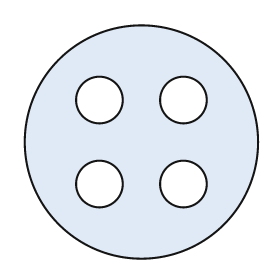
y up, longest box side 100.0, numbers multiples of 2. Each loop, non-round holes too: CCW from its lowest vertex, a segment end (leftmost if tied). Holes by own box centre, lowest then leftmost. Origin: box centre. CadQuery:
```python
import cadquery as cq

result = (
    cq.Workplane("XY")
    .moveTo(0.0, 0.0)
    .circle(50.0)
    .moveTo(-18.0, -18.0)
    .circle(10.0)
    .moveTo(18.0, -18.0)
    .circle(10.0)
    .moveTo(-18.0, 18.0)
    .circle(10.0)
    .moveTo(18.0, 18.0)
    .circle(10.0)
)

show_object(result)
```